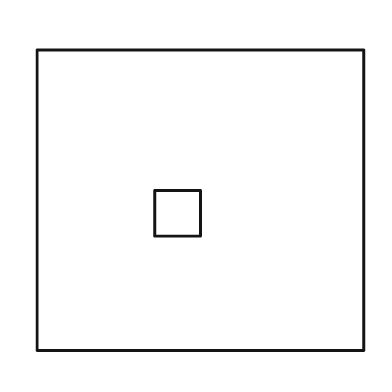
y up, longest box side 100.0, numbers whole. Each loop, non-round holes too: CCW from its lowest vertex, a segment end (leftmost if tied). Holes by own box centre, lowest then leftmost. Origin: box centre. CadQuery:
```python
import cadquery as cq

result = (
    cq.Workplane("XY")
    .moveTo(-50.0, -46.0)
    .lineTo(50.0, -46.0)
    .lineTo(50.0, 46.0)
    .lineTo(-50.0, 46.0)
    .close()
    .moveTo(-14.0, -11.0)
    .lineTo(0.0, -11.0)
    .lineTo(0.0, 3.0)
    .lineTo(-14.0, 3.0)
    .close()
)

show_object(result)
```